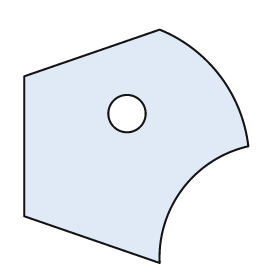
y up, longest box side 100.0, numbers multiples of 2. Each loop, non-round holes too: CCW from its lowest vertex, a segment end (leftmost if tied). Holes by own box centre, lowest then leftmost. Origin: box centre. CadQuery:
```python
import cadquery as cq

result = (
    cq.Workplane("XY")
    .moveTo(10.0, -50.0)
    .threePointArc((20.0, -18.0), (48.0, 0.0))
    .threePointArc((36.0, 30.0), (10.0, 50.0))
    .lineTo(-48.0, 30.0)
    .lineTo(-48.0, -30.0)
    .close()
    .moveTo(-4.0, 14.0)
    .circle(8.0)
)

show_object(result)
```